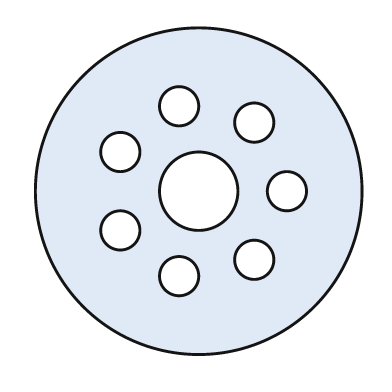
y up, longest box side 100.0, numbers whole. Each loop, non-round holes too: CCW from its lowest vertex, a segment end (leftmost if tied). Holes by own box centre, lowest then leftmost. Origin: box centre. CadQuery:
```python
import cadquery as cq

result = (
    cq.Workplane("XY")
    .moveTo(0.0, 0.0)
    .circle(50.0)
    .moveTo(-6.0, -26.0)
    .circle(6.0)
    .moveTo(17.0, -21.0)
    .circle(6.0)
    .moveTo(-24.0, -12.0)
    .circle(6.0)
    .moveTo(0.0, 0.0)
    .circle(12.0)
    .moveTo(27.0, 0.0)
    .circle(6.0)
    .moveTo(-24.0, 12.0)
    .circle(6.0)
    .moveTo(17.0, 21.0)
    .circle(6.0)
    .moveTo(-6.0, 26.0)
    .circle(6.0)
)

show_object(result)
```